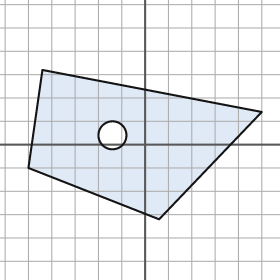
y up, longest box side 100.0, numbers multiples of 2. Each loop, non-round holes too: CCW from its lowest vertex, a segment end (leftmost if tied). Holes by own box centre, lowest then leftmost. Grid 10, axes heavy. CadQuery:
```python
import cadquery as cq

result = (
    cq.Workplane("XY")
    .moveTo(6.0, -32.0)
    .lineTo(50.0, 14.0)
    .lineTo(-44.0, 32.0)
    .lineTo(-50.0, -10.0)
    .close()
    .moveTo(-14.0, 4.0)
    .circle(6.0)
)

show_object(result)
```